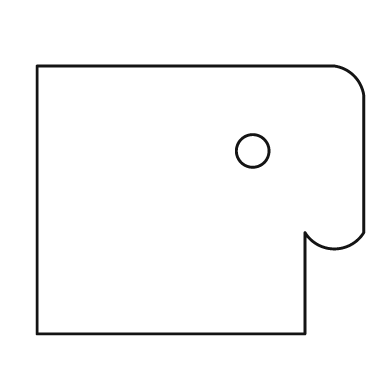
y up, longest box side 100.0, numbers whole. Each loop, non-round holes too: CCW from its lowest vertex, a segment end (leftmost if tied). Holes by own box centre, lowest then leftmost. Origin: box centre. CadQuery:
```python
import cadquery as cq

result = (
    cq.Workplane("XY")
    .moveTo(-50.0, -41.0)
    .lineTo(32.0, -41.0)
    .lineTo(32.0, -10.0)
    .threePointArc((41.0, -15.0), (50.0, -10.0))
    .lineTo(50.0, 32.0)
    .threePointArc((47.0, 38.0), (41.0, 41.0))
    .lineTo(-50.0, 41.0)
    .close()
    .moveTo(16.0, 15.0)
    .circle(5.0)
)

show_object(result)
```